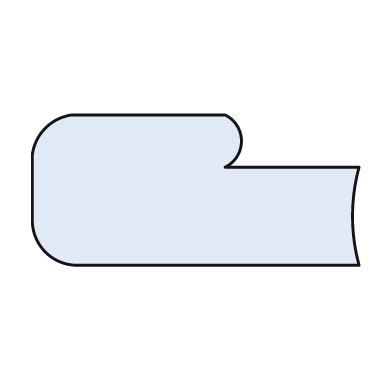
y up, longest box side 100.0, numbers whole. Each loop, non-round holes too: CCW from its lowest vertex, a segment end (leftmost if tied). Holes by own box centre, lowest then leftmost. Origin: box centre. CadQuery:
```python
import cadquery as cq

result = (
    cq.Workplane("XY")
    .moveTo(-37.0, -23.0)
    .lineTo(50.0, -23.0)
    .threePointArc((48.0, -8.0), (50.0, 7.0))
    .lineTo(9.0, 7.0)
    .threePointArc((14.0, 15.0), (9.0, 23.0))
    .lineTo(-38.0, 23.0)
    .threePointArc((-46.0, 19.0), (-50.0, 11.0))
    .lineTo(-50.0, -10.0)
    .threePointArc((-46.0, -19.0), (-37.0, -23.0))
    .close()
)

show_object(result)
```